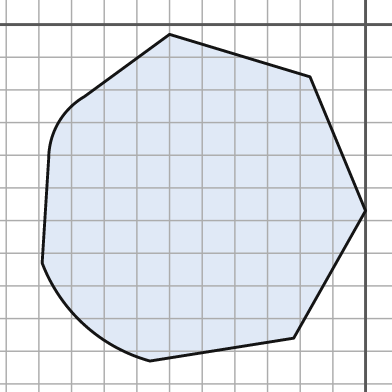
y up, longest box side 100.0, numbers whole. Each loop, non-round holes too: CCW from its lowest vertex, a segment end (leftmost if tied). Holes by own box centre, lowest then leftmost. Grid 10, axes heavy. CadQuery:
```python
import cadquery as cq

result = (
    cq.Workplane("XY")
    .moveTo(-66.0, -103.0)
    .lineTo(-22.0, -96.0)
    .lineTo(0.0, -57.0)
    .lineTo(-17.0, -16.0)
    .lineTo(-60.0, -3.0)
    .lineTo(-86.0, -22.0)
    .threePointArc((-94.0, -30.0), (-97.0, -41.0))
    .lineTo(-99.0, -73.0)
    .threePointArc((-86.0, -92.0), (-66.0, -103.0))
    .close()
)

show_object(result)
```